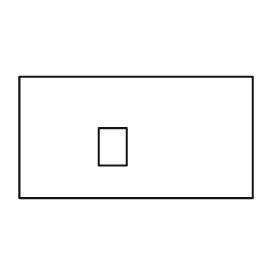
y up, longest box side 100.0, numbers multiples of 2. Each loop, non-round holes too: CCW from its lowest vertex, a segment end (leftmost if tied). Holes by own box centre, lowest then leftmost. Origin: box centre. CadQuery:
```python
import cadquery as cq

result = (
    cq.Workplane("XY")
    .moveTo(-50.0, -26.0)
    .lineTo(50.0, -26.0)
    .lineTo(50.0, 26.0)
    .lineTo(-50.0, 26.0)
    .close()
    .moveTo(-16.0, -12.0)
    .lineTo(-4.0, -12.0)
    .lineTo(-4.0, 4.0)
    .lineTo(-16.0, 4.0)
    .close()
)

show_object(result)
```